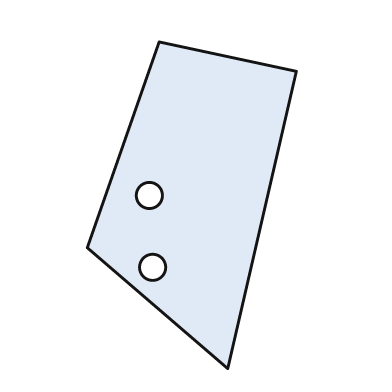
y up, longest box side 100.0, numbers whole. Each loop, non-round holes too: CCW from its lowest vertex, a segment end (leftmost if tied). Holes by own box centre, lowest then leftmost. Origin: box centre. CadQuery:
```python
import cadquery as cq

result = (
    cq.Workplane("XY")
    .moveTo(11.0, -50.0)
    .lineTo(32.0, 41.0)
    .lineTo(-10.0, 50.0)
    .lineTo(-32.0, -13.0)
    .close()
    .moveTo(-12.0, -19.0)
    .circle(4.0)
    .moveTo(-13.0, 3.0)
    .circle(4.0)
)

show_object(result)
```